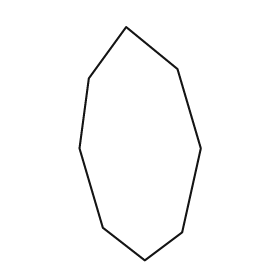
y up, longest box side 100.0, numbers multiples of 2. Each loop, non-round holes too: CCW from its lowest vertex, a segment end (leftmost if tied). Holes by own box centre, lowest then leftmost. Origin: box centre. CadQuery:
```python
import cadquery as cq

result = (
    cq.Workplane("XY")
    .moveTo(2.0, -50.0)
    .lineTo(18.0, -38.0)
    .lineTo(26.0, -2.0)
    .lineTo(16.0, 32.0)
    .lineTo(-6.0, 50.0)
    .lineTo(-22.0, 28.0)
    .lineTo(-26.0, -2.0)
    .lineTo(-16.0, -36.0)
    .close()
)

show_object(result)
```